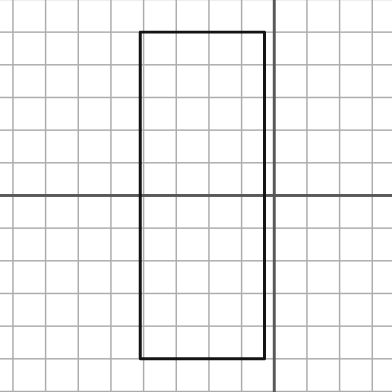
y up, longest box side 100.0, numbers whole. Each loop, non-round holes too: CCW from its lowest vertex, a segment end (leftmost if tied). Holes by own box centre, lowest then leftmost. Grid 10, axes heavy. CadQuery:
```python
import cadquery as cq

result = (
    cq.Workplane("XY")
    .moveTo(-41.0, -50.0)
    .lineTo(-3.0, -50.0)
    .lineTo(-3.0, 50.0)
    .lineTo(-41.0, 50.0)
    .close()
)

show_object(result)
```